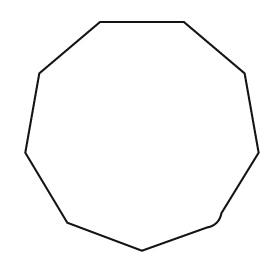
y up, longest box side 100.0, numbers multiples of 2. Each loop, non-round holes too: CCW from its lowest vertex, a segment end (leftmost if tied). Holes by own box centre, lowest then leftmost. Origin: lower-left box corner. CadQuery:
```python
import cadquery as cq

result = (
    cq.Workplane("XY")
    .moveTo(50.0, 0.0)
    .lineTo(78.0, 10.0)
    .threePointArc((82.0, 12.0), (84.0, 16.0))
    .lineTo(100.0, 42.0)
    .lineTo(94.0, 76.0)
    .lineTo(68.0, 98.0)
    .lineTo(32.0, 98.0)
    .lineTo(6.0, 76.0)
    .lineTo(0.0, 42.0)
    .lineTo(18.0, 12.0)
    .close()
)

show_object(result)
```